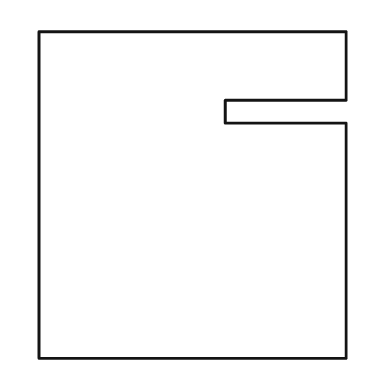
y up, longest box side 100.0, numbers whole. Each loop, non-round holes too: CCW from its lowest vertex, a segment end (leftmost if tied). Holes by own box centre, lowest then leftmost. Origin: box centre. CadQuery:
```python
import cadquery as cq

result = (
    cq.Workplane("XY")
    .moveTo(-47.0, -50.0)
    .lineTo(47.0, -50.0)
    .lineTo(47.0, 22.0)
    .lineTo(10.0, 22.0)
    .lineTo(10.0, 29.0)
    .lineTo(47.0, 29.0)
    .lineTo(47.0, 50.0)
    .lineTo(-47.0, 50.0)
    .close()
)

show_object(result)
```